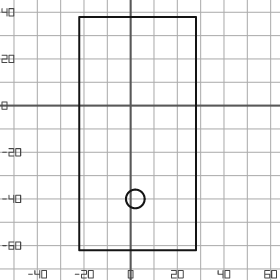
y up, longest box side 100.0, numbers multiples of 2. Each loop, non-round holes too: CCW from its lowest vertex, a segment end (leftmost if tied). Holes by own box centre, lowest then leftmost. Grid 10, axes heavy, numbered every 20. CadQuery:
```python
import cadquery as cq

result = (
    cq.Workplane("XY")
    .moveTo(-22.0, -62.0)
    .lineTo(28.0, -62.0)
    .lineTo(28.0, 38.0)
    .lineTo(-22.0, 38.0)
    .close()
    .moveTo(2.0, -40.0)
    .circle(4.0)
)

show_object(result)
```